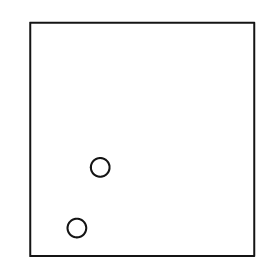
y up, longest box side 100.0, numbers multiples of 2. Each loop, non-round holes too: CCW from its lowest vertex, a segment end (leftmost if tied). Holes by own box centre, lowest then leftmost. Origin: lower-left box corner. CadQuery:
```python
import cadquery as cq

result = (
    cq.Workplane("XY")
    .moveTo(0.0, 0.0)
    .lineTo(96.0, 0.0)
    .lineTo(96.0, 100.0)
    .lineTo(0.0, 100.0)
    .close()
    .moveTo(20.0, 12.0)
    .circle(4.0)
    .moveTo(30.0, 38.0)
    .circle(4.0)
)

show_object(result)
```